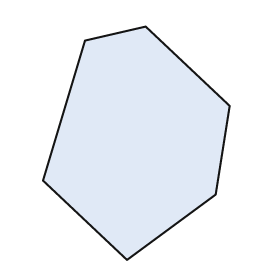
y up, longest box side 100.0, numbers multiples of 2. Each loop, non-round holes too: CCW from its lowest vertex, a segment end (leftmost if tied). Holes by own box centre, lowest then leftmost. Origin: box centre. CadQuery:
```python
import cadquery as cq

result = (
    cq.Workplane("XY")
    .moveTo(-4.0, -50.0)
    .lineTo(34.0, -22.0)
    .lineTo(40.0, 16.0)
    .lineTo(4.0, 50.0)
    .lineTo(-22.0, 44.0)
    .lineTo(-40.0, -16.0)
    .close()
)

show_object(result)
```